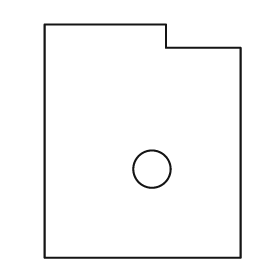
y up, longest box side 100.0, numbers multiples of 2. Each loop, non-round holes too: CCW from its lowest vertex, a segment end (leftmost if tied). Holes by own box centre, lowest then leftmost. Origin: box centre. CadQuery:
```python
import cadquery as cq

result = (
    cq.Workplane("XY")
    .moveTo(-42.0, -50.0)
    .lineTo(42.0, -50.0)
    .lineTo(42.0, 40.0)
    .lineTo(10.0, 40.0)
    .lineTo(10.0, 50.0)
    .lineTo(-42.0, 50.0)
    .close()
    .moveTo(4.0, -12.0)
    .circle(8.0)
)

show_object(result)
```